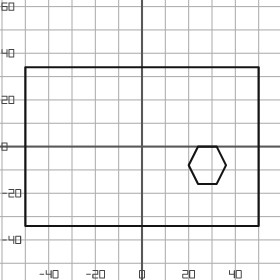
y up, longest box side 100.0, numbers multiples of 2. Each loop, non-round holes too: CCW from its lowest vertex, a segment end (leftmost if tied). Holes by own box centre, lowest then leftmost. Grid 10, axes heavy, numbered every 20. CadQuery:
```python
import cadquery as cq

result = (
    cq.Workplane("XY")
    .moveTo(-50.0, -34.0)
    .lineTo(50.0, -34.0)
    .lineTo(50.0, 34.0)
    .lineTo(-50.0, 34.0)
    .close()
    .moveTo(24.0, -16.0)
    .lineTo(32.0, -16.0)
    .lineTo(36.0, -8.0)
    .lineTo(32.0, 0.0)
    .lineTo(24.0, 0.0)
    .lineTo(20.0, -8.0)
    .close()
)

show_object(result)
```